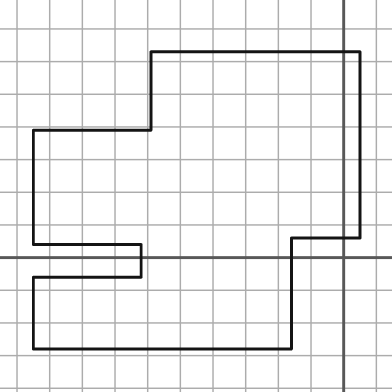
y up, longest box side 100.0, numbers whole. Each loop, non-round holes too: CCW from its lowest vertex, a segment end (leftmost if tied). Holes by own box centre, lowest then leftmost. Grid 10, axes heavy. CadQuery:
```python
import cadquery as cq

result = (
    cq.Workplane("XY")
    .moveTo(-95.0, -28.0)
    .lineTo(-16.0, -28.0)
    .lineTo(-16.0, 6.0)
    .lineTo(5.0, 6.0)
    .lineTo(5.0, 63.0)
    .lineTo(-59.0, 63.0)
    .lineTo(-59.0, 39.0)
    .lineTo(-95.0, 39.0)
    .lineTo(-95.0, 4.0)
    .lineTo(-62.0, 4.0)
    .lineTo(-62.0, -6.0)
    .lineTo(-95.0, -6.0)
    .close()
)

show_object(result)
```